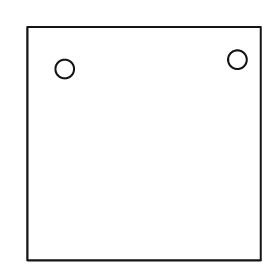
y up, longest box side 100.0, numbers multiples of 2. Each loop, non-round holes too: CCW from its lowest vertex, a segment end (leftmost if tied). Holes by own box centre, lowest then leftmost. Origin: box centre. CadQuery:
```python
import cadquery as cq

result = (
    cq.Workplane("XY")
    .moveTo(-50.0, -50.0)
    .lineTo(50.0, -50.0)
    .lineTo(50.0, 50.0)
    .lineTo(-50.0, 50.0)
    .close()
    .moveTo(-34.0, 32.0)
    .circle(4.0)
    .moveTo(40.0, 36.0)
    .circle(4.0)
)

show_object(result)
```